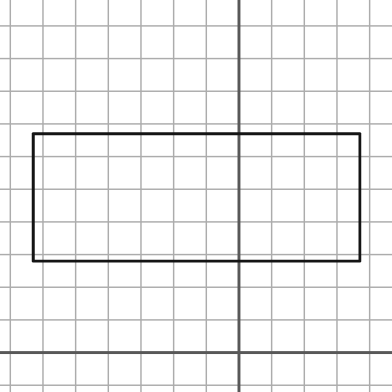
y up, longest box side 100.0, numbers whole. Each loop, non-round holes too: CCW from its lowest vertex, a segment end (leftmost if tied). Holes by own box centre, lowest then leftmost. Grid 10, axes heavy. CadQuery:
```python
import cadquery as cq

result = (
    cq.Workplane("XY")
    .moveTo(-63.0, 28.0)
    .lineTo(37.0, 28.0)
    .lineTo(37.0, 67.0)
    .lineTo(-63.0, 67.0)
    .close()
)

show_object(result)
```